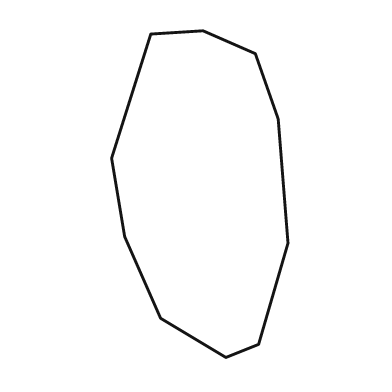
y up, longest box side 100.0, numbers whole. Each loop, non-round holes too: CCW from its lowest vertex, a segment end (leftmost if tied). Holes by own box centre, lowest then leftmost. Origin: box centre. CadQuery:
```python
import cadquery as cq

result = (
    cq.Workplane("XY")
    .moveTo(8.0, -50.0)
    .lineTo(18.0, -46.0)
    .lineTo(27.0, -15.0)
    .lineTo(24.0, 23.0)
    .lineTo(17.0, 43.0)
    .lineTo(1.0, 50.0)
    .lineTo(-15.0, 49.0)
    .lineTo(-27.0, 11.0)
    .lineTo(-23.0, -13.0)
    .lineTo(-12.0, -38.0)
    .close()
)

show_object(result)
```